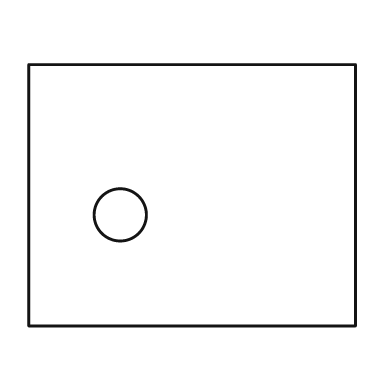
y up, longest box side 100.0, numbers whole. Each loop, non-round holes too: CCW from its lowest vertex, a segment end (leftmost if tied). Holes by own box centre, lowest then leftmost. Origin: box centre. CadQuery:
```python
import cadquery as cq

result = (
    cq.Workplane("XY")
    .moveTo(-50.0, -40.0)
    .lineTo(50.0, -40.0)
    .lineTo(50.0, 40.0)
    .lineTo(-50.0, 40.0)
    .close()
    .moveTo(-22.0, -6.0)
    .circle(8.0)
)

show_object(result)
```